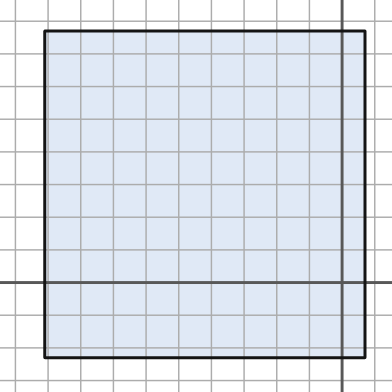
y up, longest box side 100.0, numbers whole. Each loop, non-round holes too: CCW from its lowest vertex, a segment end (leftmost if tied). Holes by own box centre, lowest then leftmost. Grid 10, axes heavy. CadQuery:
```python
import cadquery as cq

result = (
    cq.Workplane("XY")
    .moveTo(-91.0, -23.0)
    .lineTo(7.0, -23.0)
    .lineTo(7.0, 77.0)
    .lineTo(-91.0, 77.0)
    .close()
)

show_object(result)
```